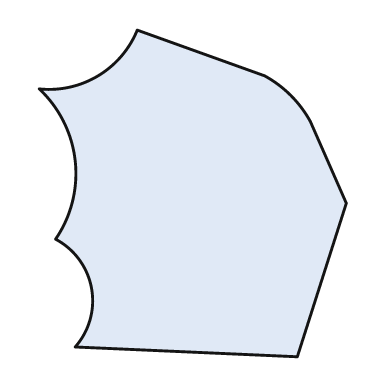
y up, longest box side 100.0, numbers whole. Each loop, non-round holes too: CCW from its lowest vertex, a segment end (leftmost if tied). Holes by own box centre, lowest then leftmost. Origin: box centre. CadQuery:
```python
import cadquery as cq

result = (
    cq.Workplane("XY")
    .moveTo(32.0, -50.0)
    .lineTo(47.0, -3.0)
    .lineTo(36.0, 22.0)
    .threePointArc((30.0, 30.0), (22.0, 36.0))
    .lineTo(-17.0, 50.0)
    .threePointArc((-29.0, 36.0), (-47.0, 32.0))
    .threePointArc((-36.0, 10.0), (-42.0, -14.0))
    .threePointArc((-31.0, -29.0), (-36.0, -47.0))
    .close()
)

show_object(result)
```